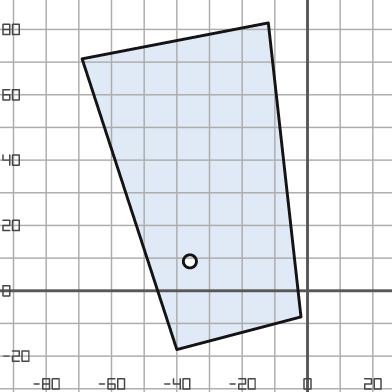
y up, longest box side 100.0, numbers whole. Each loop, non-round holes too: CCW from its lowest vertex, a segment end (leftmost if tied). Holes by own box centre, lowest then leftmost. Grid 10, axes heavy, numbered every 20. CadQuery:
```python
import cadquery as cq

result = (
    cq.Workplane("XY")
    .moveTo(-40.0, -18.0)
    .lineTo(-2.0, -8.0)
    .lineTo(-12.0, 82.0)
    .lineTo(-69.0, 71.0)
    .close()
    .moveTo(-36.0, 9.0)
    .circle(2.0)
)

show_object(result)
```